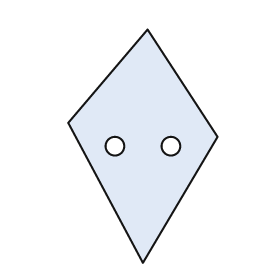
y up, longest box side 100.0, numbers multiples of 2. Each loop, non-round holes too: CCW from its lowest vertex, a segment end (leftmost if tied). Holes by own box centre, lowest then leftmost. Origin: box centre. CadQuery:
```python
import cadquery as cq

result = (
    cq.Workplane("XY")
    .moveTo(0.0, -50.0)
    .lineTo(32.0, 4.0)
    .lineTo(2.0, 50.0)
    .lineTo(-32.0, 10.0)
    .close()
    .moveTo(-12.0, 0.0)
    .circle(4.0)
    .moveTo(12.0, 0.0)
    .circle(4.0)
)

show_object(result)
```